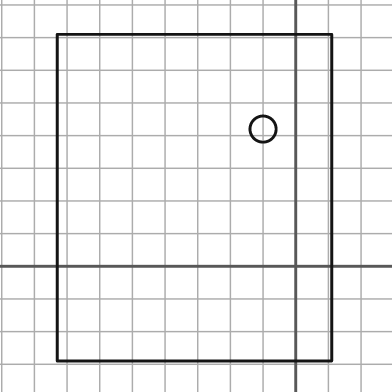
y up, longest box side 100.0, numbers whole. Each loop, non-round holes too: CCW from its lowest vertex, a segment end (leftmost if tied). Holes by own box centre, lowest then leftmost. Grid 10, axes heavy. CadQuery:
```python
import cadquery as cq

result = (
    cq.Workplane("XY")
    .moveTo(-73.0, -29.0)
    .lineTo(11.0, -29.0)
    .lineTo(11.0, 71.0)
    .lineTo(-73.0, 71.0)
    .close()
    .moveTo(-10.0, 42.0)
    .circle(4.0)
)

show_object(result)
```